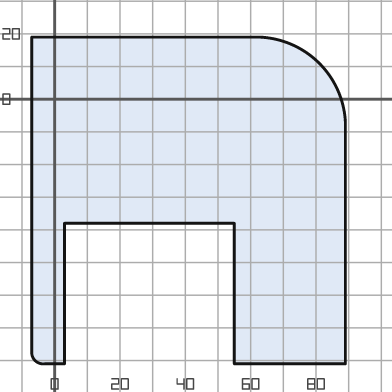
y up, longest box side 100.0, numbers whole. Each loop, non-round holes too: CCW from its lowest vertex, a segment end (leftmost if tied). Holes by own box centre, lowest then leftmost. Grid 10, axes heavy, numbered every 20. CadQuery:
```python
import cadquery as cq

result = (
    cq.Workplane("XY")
    .moveTo(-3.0, -81.0)
    .lineTo(3.0, -81.0)
    .lineTo(3.0, -38.0)
    .lineTo(55.0, -38.0)
    .lineTo(55.0, -81.0)
    .lineTo(89.0, -81.0)
    .lineTo(89.0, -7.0)
    .threePointArc((81.0, 11.0), (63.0, 19.0))
    .lineTo(-7.0, 19.0)
    .lineTo(-7.0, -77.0)
    .threePointArc((-6.0, -80.0), (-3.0, -81.0))
    .close()
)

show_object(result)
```